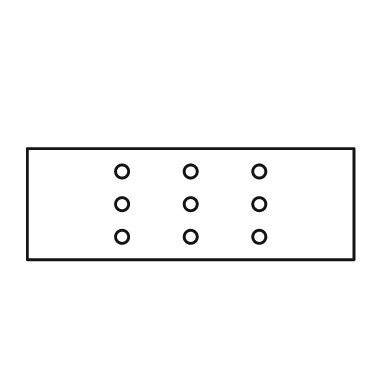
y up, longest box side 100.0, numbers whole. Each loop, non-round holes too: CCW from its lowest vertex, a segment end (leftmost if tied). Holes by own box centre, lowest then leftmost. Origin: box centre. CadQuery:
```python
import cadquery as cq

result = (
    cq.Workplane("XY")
    .moveTo(-50.0, -17.0)
    .lineTo(50.0, -17.0)
    .lineTo(50.0, 17.0)
    .lineTo(-50.0, 17.0)
    .close()
    .moveTo(-21.0, -10.0)
    .circle(2.0)
    .moveTo(0.0, -10.0)
    .circle(2.0)
    .moveTo(21.0, -10.0)
    .circle(2.0)
    .moveTo(-21.0, 0.0)
    .circle(2.0)
    .moveTo(0.0, 0.0)
    .circle(2.0)
    .moveTo(21.0, 0.0)
    .circle(2.0)
    .moveTo(-21.0, 10.0)
    .circle(2.0)
    .moveTo(0.0, 10.0)
    .circle(2.0)
    .moveTo(21.0, 10.0)
    .circle(2.0)
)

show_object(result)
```